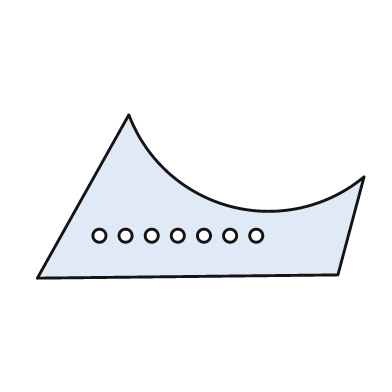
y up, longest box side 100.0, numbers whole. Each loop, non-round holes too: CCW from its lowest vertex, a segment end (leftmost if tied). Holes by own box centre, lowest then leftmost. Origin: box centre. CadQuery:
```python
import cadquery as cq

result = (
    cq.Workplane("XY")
    .moveTo(-50.0, -25.0)
    .lineTo(42.0, -24.0)
    .lineTo(50.0, 6.0)
    .threePointArc((9.0, -3.0), (-22.0, 25.0))
    .close()
    .moveTo(-31.0, -12.0)
    .circle(2.0)
    .moveTo(-23.0, -12.0)
    .circle(2.0)
    .moveTo(-15.0, -12.0)
    .circle(2.0)
    .moveTo(-7.0, -12.0)
    .circle(2.0)
    .moveTo(1.0, -12.0)
    .circle(2.0)
    .moveTo(9.0, -12.0)
    .circle(2.0)
    .moveTo(17.0, -12.0)
    .circle(2.0)
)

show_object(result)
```